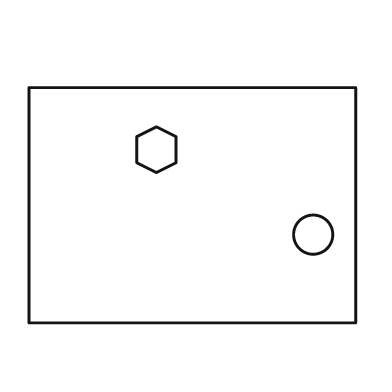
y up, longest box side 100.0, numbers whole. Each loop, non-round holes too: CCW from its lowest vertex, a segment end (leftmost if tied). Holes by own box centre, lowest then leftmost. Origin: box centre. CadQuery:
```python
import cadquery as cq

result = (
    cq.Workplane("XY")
    .moveTo(-50.0, -36.0)
    .lineTo(50.0, -36.0)
    .lineTo(50.0, 36.0)
    .lineTo(-50.0, 36.0)
    .close()
    .moveTo(37.0, -9.0)
    .circle(6.0)
    .moveTo(-11.0, 10.0)
    .lineTo(-5.0, 13.0)
    .lineTo(-5.0, 21.0)
    .lineTo(-11.0, 24.0)
    .lineTo(-17.0, 21.0)
    .lineTo(-17.0, 13.0)
    .close()
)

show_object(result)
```